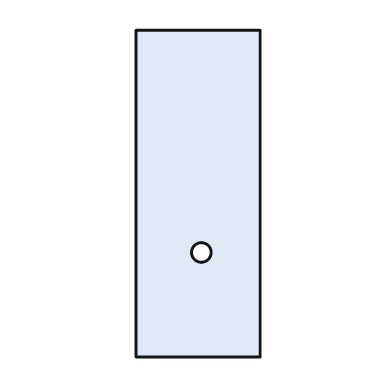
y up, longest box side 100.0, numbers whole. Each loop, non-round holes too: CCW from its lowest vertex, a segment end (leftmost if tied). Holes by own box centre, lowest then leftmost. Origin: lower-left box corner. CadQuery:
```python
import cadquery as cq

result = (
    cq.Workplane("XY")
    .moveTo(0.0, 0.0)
    .lineTo(38.0, 0.0)
    .lineTo(38.0, 100.0)
    .lineTo(0.0, 100.0)
    .close()
    .moveTo(20.0, 32.0)
    .circle(3.0)
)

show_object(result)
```